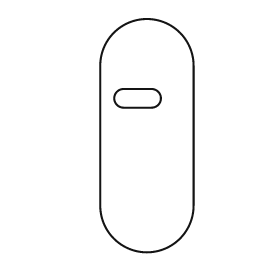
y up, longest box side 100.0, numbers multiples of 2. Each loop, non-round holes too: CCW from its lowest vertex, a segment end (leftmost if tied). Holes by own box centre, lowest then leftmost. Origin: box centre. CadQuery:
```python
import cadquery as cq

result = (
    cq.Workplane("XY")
    .moveTo(-20.0, -30.0)
    .threePointArc((0.0, -50.0), (20.0, -30.0))
    .lineTo(20.0, 30.0)
    .threePointArc((0.0, 50.0), (-20.0, 30.0))
    .close()
    .moveTo(-10.0, 12.0)
    .lineTo(2.0, 12.0)
    .threePointArc((6.0, 16.0), (2.0, 20.0))
    .lineTo(-10.0, 20.0)
    .threePointArc((-14.0, 16.0), (-10.0, 12.0))
    .close()
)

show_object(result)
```